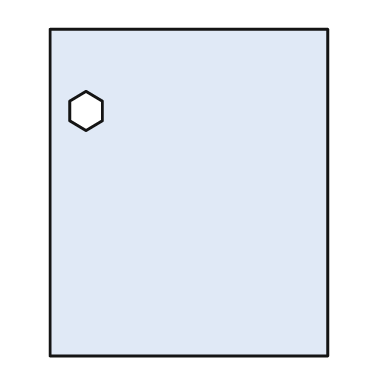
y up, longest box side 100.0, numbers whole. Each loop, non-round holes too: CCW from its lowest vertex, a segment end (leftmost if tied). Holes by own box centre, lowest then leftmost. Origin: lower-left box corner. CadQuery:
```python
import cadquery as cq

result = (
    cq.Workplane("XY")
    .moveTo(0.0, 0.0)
    .lineTo(85.0, 0.0)
    .lineTo(85.0, 100.0)
    .lineTo(0.0, 100.0)
    .close()
    .moveTo(11.0, 69.0)
    .lineTo(16.0, 72.0)
    .lineTo(16.0, 78.0)
    .lineTo(11.0, 81.0)
    .lineTo(6.0, 78.0)
    .lineTo(6.0, 72.0)
    .close()
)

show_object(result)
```